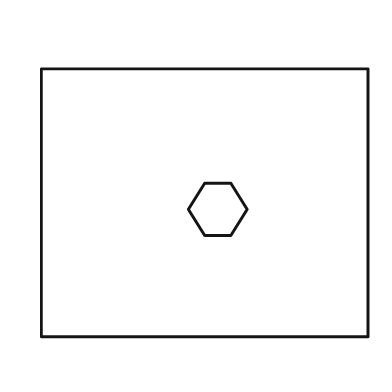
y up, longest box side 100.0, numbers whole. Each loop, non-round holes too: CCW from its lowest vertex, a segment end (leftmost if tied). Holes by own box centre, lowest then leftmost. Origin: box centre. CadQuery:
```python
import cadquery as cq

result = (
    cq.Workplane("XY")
    .moveTo(-50.0, -41.0)
    .lineTo(50.0, -41.0)
    .lineTo(50.0, 41.0)
    .lineTo(-50.0, 41.0)
    .close()
    .moveTo(0.0, -10.0)
    .lineTo(8.0, -10.0)
    .lineTo(13.0, -2.0)
    .lineTo(8.0, 6.0)
    .lineTo(0.0, 6.0)
    .lineTo(-5.0, -2.0)
    .close()
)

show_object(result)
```